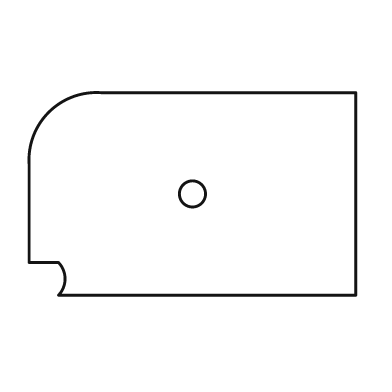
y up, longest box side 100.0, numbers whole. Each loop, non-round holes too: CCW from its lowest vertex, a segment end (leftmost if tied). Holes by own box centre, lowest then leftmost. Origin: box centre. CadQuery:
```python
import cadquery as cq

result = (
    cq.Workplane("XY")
    .moveTo(-41.0, -31.0)
    .lineTo(50.0, -31.0)
    .lineTo(50.0, 31.0)
    .lineTo(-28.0, 31.0)
    .threePointArc((-44.0, 25.0), (-50.0, 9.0))
    .lineTo(-50.0, -21.0)
    .lineTo(-41.0, -21.0)
    .threePointArc((-39.0, -26.0), (-41.0, -31.0))
    .close()
    .moveTo(0.0, 0.0)
    .circle(4.0)
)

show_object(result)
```